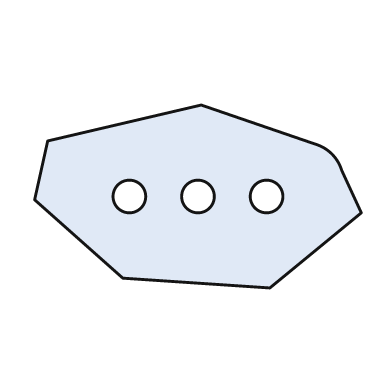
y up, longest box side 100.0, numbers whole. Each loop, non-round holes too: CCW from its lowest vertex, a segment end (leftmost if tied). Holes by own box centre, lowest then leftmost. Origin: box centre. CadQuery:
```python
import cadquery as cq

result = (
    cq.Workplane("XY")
    .moveTo(22.0, -28.0)
    .lineTo(50.0, -5.0)
    .lineTo(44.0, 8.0)
    .threePointArc((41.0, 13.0), (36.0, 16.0))
    .lineTo(1.0, 28.0)
    .lineTo(-46.0, 17.0)
    .lineTo(-50.0, -1.0)
    .lineTo(-23.0, -25.0)
    .close()
    .moveTo(-21.0, 0.0)
    .circle(5.0)
    .moveTo(0.0, 0.0)
    .circle(5.0)
    .moveTo(21.0, 0.0)
    .circle(5.0)
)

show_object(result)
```